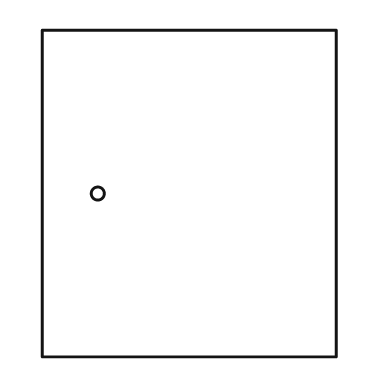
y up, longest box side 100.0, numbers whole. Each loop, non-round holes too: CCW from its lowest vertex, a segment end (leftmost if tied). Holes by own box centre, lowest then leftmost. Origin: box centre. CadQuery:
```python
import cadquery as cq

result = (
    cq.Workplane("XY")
    .moveTo(-45.0, -50.0)
    .lineTo(45.0, -50.0)
    .lineTo(45.0, 50.0)
    .lineTo(-45.0, 50.0)
    .close()
    .moveTo(-28.0, 0.0)
    .circle(2.0)
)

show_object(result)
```